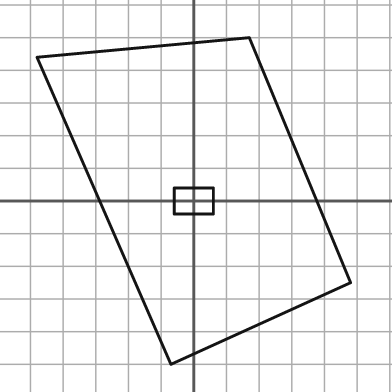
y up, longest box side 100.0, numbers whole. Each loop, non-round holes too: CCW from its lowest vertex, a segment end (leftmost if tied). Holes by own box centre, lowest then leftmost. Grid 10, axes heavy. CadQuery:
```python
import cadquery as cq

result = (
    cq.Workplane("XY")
    .moveTo(-7.0, -50.0)
    .lineTo(48.0, -25.0)
    .lineTo(17.0, 50.0)
    .lineTo(-48.0, 44.0)
    .close()
    .moveTo(-6.0, -4.0)
    .lineTo(6.0, -4.0)
    .lineTo(6.0, 4.0)
    .lineTo(-6.0, 4.0)
    .close()
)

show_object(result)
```